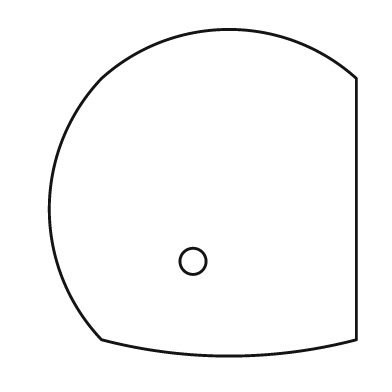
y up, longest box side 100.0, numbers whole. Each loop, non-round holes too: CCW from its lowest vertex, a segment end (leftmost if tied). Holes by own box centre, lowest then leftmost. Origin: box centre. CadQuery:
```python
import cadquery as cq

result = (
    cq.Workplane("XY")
    .moveTo(-31.0, -45.0)
    .threePointArc((8.0, -50.0), (47.0, -45.0))
    .lineTo(47.0, 35.0)
    .threePointArc((8.0, 50.0), (-31.0, 35.0))
    .threePointArc((-47.0, -5.0), (-31.0, -45.0))
    .close()
    .moveTo(-3.0, -21.0)
    .circle(4.0)
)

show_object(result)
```